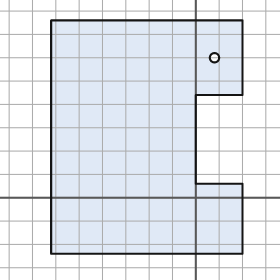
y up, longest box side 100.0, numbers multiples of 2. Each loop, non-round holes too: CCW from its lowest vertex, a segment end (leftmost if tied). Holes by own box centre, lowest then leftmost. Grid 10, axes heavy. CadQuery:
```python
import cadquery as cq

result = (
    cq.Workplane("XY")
    .moveTo(-62.0, -24.0)
    .lineTo(20.0, -24.0)
    .lineTo(20.0, 6.0)
    .lineTo(0.0, 6.0)
    .lineTo(0.0, 44.0)
    .lineTo(20.0, 44.0)
    .lineTo(20.0, 76.0)
    .lineTo(-62.0, 76.0)
    .close()
    .moveTo(8.0, 60.0)
    .circle(2.0)
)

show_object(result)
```